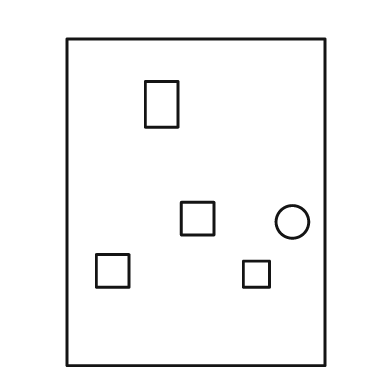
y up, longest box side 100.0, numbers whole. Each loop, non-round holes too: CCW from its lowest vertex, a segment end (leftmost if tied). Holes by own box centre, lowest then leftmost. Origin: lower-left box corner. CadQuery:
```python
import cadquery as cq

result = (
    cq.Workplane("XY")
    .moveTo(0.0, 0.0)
    .lineTo(79.0, 0.0)
    .lineTo(79.0, 100.0)
    .lineTo(0.0, 100.0)
    .close()
    .moveTo(54.0, 24.0)
    .lineTo(62.0, 24.0)
    .lineTo(62.0, 32.0)
    .lineTo(54.0, 32.0)
    .close()
    .moveTo(9.0, 24.0)
    .lineTo(19.0, 24.0)
    .lineTo(19.0, 34.0)
    .lineTo(9.0, 34.0)
    .close()
    .moveTo(69.0, 44.0)
    .circle(5.0)
    .moveTo(35.0, 40.0)
    .lineTo(45.0, 40.0)
    .lineTo(45.0, 50.0)
    .lineTo(35.0, 50.0)
    .close()
    .moveTo(24.0, 73.0)
    .lineTo(34.0, 73.0)
    .lineTo(34.0, 87.0)
    .lineTo(24.0, 87.0)
    .close()
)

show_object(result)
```